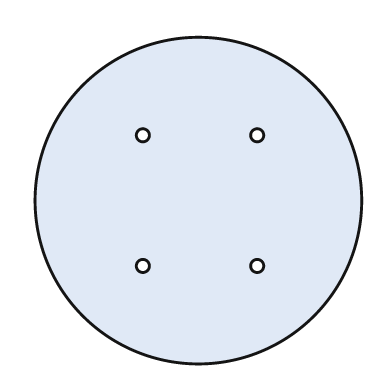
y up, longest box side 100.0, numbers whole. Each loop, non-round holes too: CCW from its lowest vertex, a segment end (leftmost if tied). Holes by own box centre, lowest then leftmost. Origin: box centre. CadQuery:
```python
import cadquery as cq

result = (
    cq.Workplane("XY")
    .moveTo(0.0, 0.0)
    .circle(50.0)
    .moveTo(-17.0, -20.0)
    .circle(2.0)
    .moveTo(18.0, -20.0)
    .circle(2.0)
    .moveTo(-17.0, 20.0)
    .circle(2.0)
    .moveTo(18.0, 20.0)
    .circle(2.0)
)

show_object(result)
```